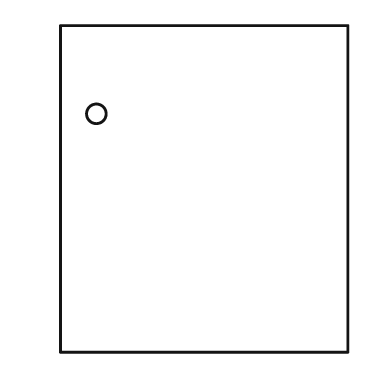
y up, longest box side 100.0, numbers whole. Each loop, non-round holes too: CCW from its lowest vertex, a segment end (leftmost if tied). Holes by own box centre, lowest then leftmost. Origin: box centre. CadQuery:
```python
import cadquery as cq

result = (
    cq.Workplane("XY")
    .moveTo(-44.0, -50.0)
    .lineTo(44.0, -50.0)
    .lineTo(44.0, 50.0)
    .lineTo(-44.0, 50.0)
    .close()
    .moveTo(-33.0, 23.0)
    .circle(3.0)
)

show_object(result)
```